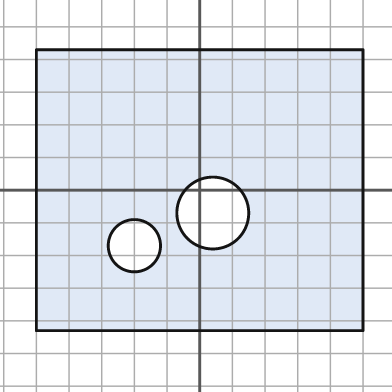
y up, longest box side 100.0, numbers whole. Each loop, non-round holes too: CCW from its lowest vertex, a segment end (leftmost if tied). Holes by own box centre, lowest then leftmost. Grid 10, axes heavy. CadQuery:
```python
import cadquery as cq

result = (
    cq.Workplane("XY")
    .moveTo(-50.0, -43.0)
    .lineTo(50.0, -43.0)
    .lineTo(50.0, 43.0)
    .lineTo(-50.0, 43.0)
    .close()
    .moveTo(-20.0, -17.0)
    .circle(8.0)
    .moveTo(4.0, -7.0)
    .circle(11.0)
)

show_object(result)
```